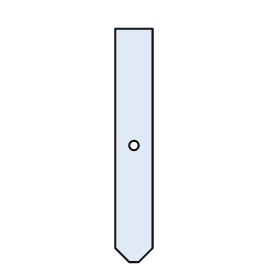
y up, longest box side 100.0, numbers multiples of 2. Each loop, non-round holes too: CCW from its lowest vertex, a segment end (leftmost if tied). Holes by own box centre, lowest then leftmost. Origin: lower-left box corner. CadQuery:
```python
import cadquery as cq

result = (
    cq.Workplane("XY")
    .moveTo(6.0, 0.0)
    .lineTo(10.0, 0.0)
    .lineTo(16.0, 6.0)
    .lineTo(16.0, 100.0)
    .lineTo(0.0, 100.0)
    .lineTo(0.0, 6.0)
    .close()
    .moveTo(8.0, 50.0)
    .circle(2.0)
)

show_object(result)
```